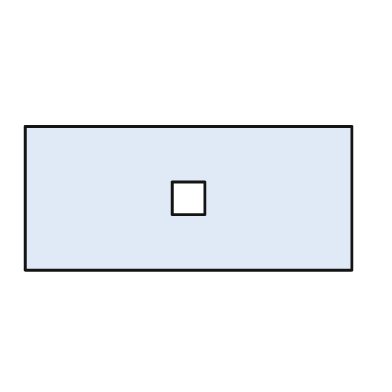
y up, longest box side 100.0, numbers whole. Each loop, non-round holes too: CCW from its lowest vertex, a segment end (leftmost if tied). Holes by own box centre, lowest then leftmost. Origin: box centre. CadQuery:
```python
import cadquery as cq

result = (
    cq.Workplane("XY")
    .moveTo(-50.0, -22.0)
    .lineTo(50.0, -22.0)
    .lineTo(50.0, 22.0)
    .lineTo(-50.0, 22.0)
    .close()
    .moveTo(-5.0, -5.0)
    .lineTo(5.0, -5.0)
    .lineTo(5.0, 5.0)
    .lineTo(-5.0, 5.0)
    .close()
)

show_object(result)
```